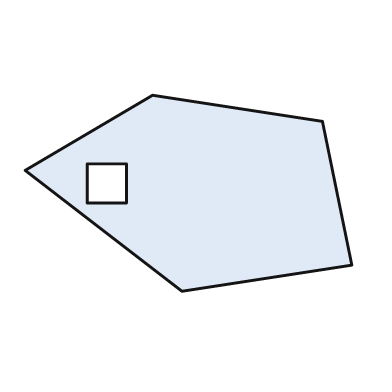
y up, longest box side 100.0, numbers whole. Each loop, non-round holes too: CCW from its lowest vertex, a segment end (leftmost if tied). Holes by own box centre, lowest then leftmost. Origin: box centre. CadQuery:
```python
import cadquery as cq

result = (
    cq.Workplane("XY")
    .moveTo(-2.0, -30.0)
    .lineTo(50.0, -22.0)
    .lineTo(41.0, 22.0)
    .lineTo(-11.0, 30.0)
    .lineTo(-50.0, 7.0)
    .close()
    .moveTo(-31.0, -3.0)
    .lineTo(-19.0, -3.0)
    .lineTo(-19.0, 9.0)
    .lineTo(-31.0, 9.0)
    .close()
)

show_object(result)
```